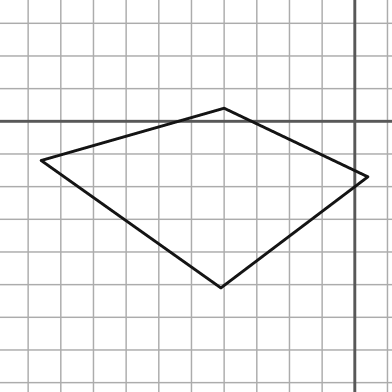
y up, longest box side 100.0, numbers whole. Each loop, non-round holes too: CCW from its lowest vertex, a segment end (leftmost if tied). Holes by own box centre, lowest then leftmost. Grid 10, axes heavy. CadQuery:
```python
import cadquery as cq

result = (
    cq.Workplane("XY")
    .moveTo(-41.0, -51.0)
    .lineTo(4.0, -17.0)
    .lineTo(-40.0, 4.0)
    .lineTo(-96.0, -12.0)
    .close()
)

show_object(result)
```